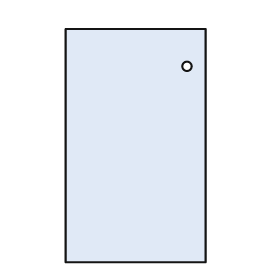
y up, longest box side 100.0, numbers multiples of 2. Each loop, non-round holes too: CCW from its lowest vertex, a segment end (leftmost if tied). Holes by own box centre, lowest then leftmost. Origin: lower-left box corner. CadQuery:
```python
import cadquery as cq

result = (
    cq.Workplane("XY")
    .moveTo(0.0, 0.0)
    .lineTo(60.0, 0.0)
    .lineTo(60.0, 100.0)
    .lineTo(0.0, 100.0)
    .close()
    .moveTo(52.0, 84.0)
    .circle(2.0)
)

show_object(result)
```